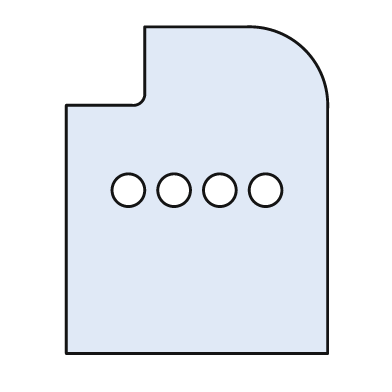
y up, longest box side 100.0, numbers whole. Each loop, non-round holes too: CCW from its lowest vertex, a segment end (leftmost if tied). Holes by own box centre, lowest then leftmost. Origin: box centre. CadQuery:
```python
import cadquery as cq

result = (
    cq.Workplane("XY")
    .moveTo(-40.0, -50.0)
    .lineTo(40.0, -50.0)
    .lineTo(40.0, 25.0)
    .threePointArc((33.0, 43.0), (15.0, 50.0))
    .lineTo(-16.0, 50.0)
    .lineTo(-16.0, 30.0)
    .threePointArc((-17.0, 27.0), (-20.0, 26.0))
    .lineTo(-40.0, 26.0)
    .close()
    .moveTo(-21.0, 0.0)
    .circle(5.0)
    .moveTo(-7.0, 0.0)
    .circle(5.0)
    .moveTo(7.0, 0.0)
    .circle(5.0)
    .moveTo(21.0, 0.0)
    .circle(5.0)
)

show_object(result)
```